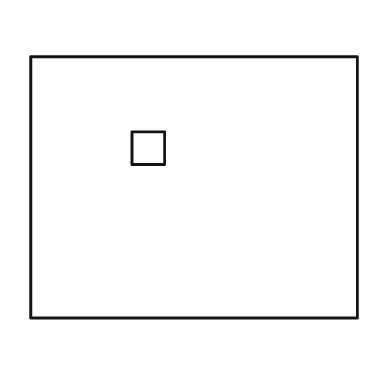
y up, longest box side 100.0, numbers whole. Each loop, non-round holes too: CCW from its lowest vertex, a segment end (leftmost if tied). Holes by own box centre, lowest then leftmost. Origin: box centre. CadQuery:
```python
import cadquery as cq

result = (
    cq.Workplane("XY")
    .moveTo(-50.0, -40.0)
    .lineTo(50.0, -40.0)
    .lineTo(50.0, 40.0)
    .lineTo(-50.0, 40.0)
    .close()
    .moveTo(-19.0, 7.0)
    .lineTo(-9.0, 7.0)
    .lineTo(-9.0, 17.0)
    .lineTo(-19.0, 17.0)
    .close()
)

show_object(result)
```